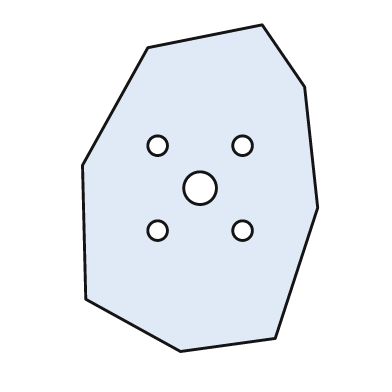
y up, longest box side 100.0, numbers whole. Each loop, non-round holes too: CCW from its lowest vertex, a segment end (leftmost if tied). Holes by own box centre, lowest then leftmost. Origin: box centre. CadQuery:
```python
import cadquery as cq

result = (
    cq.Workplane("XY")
    .moveTo(-6.0, -50.0)
    .lineTo(23.0, -46.0)
    .lineTo(36.0, -6.0)
    .lineTo(32.0, 31.0)
    .lineTo(19.0, 50.0)
    .lineTo(-16.0, 43.0)
    .lineTo(-36.0, 7.0)
    .lineTo(-35.0, -34.0)
    .close()
    .moveTo(-13.0, -13.0)
    .circle(3.0)
    .moveTo(13.0, -13.0)
    .circle(3.0)
    .moveTo(0.0, 0.0)
    .circle(5.0)
    .moveTo(-13.0, 13.0)
    .circle(3.0)
    .moveTo(13.0, 13.0)
    .circle(3.0)
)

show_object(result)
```